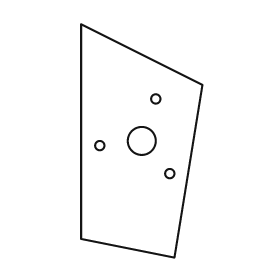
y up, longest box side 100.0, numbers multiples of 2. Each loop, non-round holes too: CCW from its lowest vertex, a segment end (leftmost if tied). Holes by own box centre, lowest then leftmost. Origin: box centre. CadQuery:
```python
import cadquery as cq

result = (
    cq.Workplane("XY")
    .moveTo(14.0, -50.0)
    .lineTo(26.0, 24.0)
    .lineTo(-26.0, 50.0)
    .lineTo(-26.0, -42.0)
    .close()
    .moveTo(12.0, -14.0)
    .circle(2.0)
    .moveTo(-18.0, -2.0)
    .circle(2.0)
    .moveTo(0.0, 0.0)
    .circle(6.0)
    .moveTo(6.0, 18.0)
    .circle(2.0)
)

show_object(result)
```